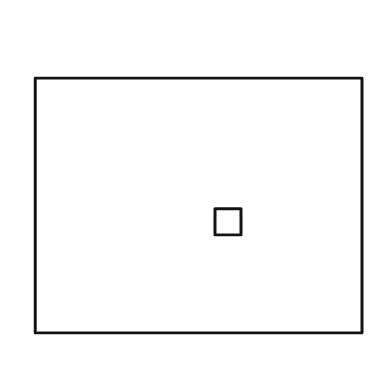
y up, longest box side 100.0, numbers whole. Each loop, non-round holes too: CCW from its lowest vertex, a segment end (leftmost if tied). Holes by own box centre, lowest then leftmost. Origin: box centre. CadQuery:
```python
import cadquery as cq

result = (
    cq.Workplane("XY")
    .moveTo(-50.0, -39.0)
    .lineTo(50.0, -39.0)
    .lineTo(50.0, 39.0)
    .lineTo(-50.0, 39.0)
    .close()
    .moveTo(5.0, -9.0)
    .lineTo(13.0, -9.0)
    .lineTo(13.0, -1.0)
    .lineTo(5.0, -1.0)
    .close()
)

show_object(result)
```